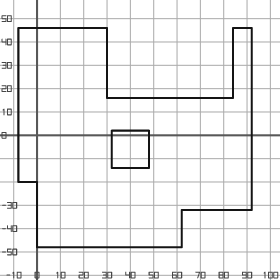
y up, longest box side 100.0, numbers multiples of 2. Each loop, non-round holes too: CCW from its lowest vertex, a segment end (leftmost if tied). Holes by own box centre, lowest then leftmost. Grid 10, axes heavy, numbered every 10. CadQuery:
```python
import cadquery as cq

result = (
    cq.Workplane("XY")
    .moveTo(0.0, -48.0)
    .lineTo(62.0, -48.0)
    .lineTo(62.0, -32.0)
    .lineTo(92.0, -32.0)
    .lineTo(92.0, 46.0)
    .lineTo(84.0, 46.0)
    .lineTo(84.0, 16.0)
    .lineTo(30.0, 16.0)
    .lineTo(30.0, 46.0)
    .lineTo(-8.0, 46.0)
    .lineTo(-8.0, -20.0)
    .lineTo(0.0, -20.0)
    .close()
    .moveTo(32.0, -14.0)
    .lineTo(48.0, -14.0)
    .lineTo(48.0, 2.0)
    .lineTo(32.0, 2.0)
    .close()
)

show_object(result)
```